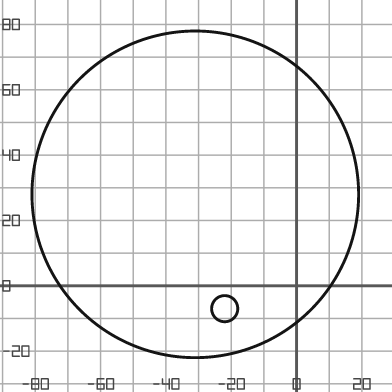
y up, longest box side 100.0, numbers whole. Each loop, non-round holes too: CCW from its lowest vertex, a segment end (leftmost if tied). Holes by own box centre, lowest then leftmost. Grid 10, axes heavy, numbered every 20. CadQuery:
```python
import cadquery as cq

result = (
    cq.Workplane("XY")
    .moveTo(-31.0, 28.0)
    .circle(50.0)
    .moveTo(-22.0, -7.0)
    .circle(4.0)
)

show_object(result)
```